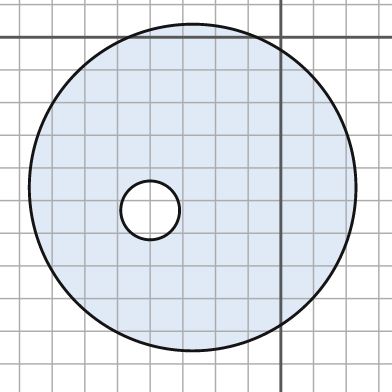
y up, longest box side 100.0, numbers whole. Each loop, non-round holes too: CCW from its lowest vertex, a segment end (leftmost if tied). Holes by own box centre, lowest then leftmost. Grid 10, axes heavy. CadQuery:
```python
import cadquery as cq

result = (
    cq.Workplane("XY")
    .moveTo(-27.0, -46.0)
    .circle(50.0)
    .moveTo(-40.0, -53.0)
    .circle(9.0)
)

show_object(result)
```